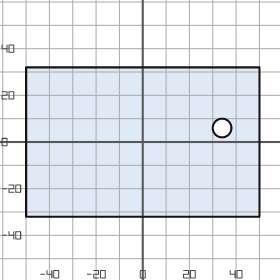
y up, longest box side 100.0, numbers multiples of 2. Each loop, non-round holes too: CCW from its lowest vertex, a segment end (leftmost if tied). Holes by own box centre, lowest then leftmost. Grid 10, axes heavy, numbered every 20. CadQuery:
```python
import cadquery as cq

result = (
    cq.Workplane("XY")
    .moveTo(-50.0, -32.0)
    .lineTo(50.0, -32.0)
    .lineTo(50.0, 32.0)
    .lineTo(-50.0, 32.0)
    .close()
    .moveTo(34.0, 6.0)
    .circle(4.0)
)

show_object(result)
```